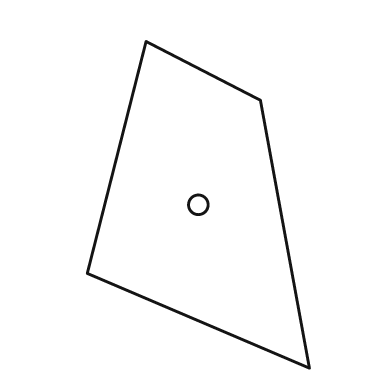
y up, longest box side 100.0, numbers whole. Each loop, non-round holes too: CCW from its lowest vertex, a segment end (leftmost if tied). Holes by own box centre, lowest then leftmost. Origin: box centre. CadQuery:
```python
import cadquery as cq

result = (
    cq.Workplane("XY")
    .moveTo(34.0, -50.0)
    .lineTo(19.0, 32.0)
    .lineTo(-16.0, 50.0)
    .lineTo(-34.0, -21.0)
    .close()
    .moveTo(0.0, 0.0)
    .circle(3.0)
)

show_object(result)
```